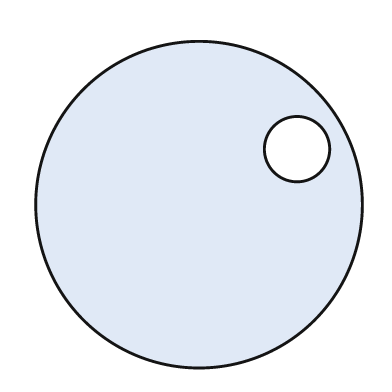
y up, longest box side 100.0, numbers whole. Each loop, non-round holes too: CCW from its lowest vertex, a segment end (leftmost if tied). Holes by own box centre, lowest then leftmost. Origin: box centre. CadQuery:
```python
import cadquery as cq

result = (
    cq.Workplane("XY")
    .moveTo(0.0, 0.0)
    .circle(50.0)
    .moveTo(30.0, 17.0)
    .circle(10.0)
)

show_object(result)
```